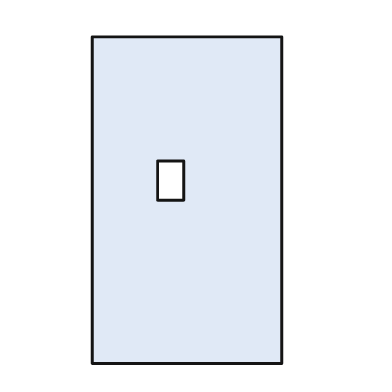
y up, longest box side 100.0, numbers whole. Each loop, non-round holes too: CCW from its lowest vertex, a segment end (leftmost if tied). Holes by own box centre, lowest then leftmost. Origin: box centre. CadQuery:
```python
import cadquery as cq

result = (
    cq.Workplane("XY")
    .moveTo(-29.0, -50.0)
    .lineTo(29.0, -50.0)
    .lineTo(29.0, 50.0)
    .lineTo(-29.0, 50.0)
    .close()
    .moveTo(-9.0, 0.0)
    .lineTo(-1.0, 0.0)
    .lineTo(-1.0, 12.0)
    .lineTo(-9.0, 12.0)
    .close()
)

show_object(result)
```